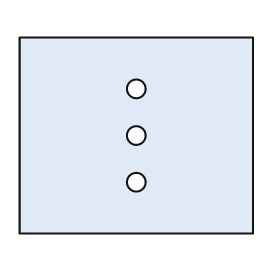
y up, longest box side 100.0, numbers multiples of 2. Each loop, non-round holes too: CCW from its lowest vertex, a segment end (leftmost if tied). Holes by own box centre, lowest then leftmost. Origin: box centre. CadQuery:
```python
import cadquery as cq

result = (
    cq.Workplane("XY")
    .moveTo(-50.0, -42.0)
    .lineTo(50.0, -42.0)
    .lineTo(50.0, 42.0)
    .lineTo(-50.0, 42.0)
    .close()
    .moveTo(0.0, -20.0)
    .circle(4.0)
    .moveTo(0.0, 0.0)
    .circle(4.0)
    .moveTo(0.0, 20.0)
    .circle(4.0)
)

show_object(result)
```